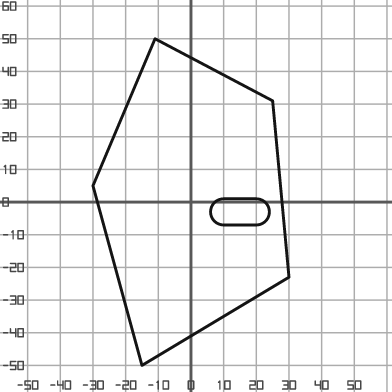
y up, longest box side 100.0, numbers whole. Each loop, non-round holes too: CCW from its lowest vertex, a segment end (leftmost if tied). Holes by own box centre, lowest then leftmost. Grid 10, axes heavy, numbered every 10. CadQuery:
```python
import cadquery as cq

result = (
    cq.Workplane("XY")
    .moveTo(-15.0, -50.0)
    .lineTo(30.0, -23.0)
    .lineTo(25.0, 31.0)
    .lineTo(-11.0, 50.0)
    .lineTo(-30.0, 5.0)
    .close()
    .moveTo(10.0, -7.0)
    .lineTo(20.0, -7.0)
    .threePointArc((24.0, -3.0), (20.0, 1.0))
    .lineTo(10.0, 1.0)
    .threePointArc((6.0, -3.0), (10.0, -7.0))
    .close()
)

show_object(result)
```